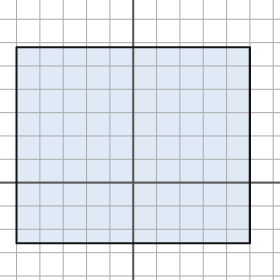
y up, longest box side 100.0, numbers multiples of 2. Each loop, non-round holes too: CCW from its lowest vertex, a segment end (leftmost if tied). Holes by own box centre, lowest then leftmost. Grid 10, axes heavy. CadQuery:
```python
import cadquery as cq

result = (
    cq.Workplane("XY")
    .moveTo(-50.0, -26.0)
    .lineTo(50.0, -26.0)
    .lineTo(50.0, 58.0)
    .lineTo(-50.0, 58.0)
    .close()
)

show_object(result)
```